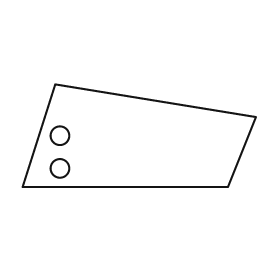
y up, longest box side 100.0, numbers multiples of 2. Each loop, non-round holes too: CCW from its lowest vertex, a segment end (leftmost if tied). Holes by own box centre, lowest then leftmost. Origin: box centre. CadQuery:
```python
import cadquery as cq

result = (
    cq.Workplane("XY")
    .moveTo(-50.0, -22.0)
    .lineTo(38.0, -22.0)
    .lineTo(50.0, 8.0)
    .lineTo(-36.0, 22.0)
    .close()
    .moveTo(-34.0, -14.0)
    .circle(4.0)
    .moveTo(-34.0, 0.0)
    .circle(4.0)
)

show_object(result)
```